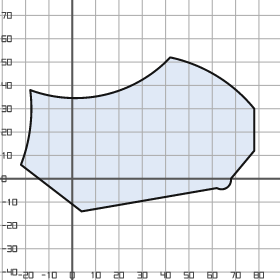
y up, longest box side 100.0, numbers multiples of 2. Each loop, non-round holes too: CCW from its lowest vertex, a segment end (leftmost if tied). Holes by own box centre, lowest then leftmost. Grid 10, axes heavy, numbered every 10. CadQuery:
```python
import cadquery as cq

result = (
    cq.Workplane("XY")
    .moveTo(4.0, -14.0)
    .lineTo(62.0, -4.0)
    .threePointArc((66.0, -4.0), (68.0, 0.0))
    .lineTo(78.0, 12.0)
    .lineTo(78.0, 30.0)
    .threePointArc((62.0, 44.0), (42.0, 52.0))
    .threePointArc((14.0, 36.0), (-18.0, 38.0))
    .threePointArc((-18.0, 22.0), (-22.0, 6.0))
    .close()
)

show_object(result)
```